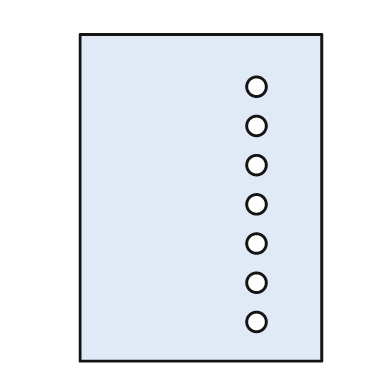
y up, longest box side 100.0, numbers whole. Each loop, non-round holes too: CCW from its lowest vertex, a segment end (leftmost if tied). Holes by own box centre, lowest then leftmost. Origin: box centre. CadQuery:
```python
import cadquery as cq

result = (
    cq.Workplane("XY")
    .moveTo(-37.0, -50.0)
    .lineTo(37.0, -50.0)
    .lineTo(37.0, 50.0)
    .lineTo(-37.0, 50.0)
    .close()
    .moveTo(17.0, -38.0)
    .circle(3.0)
    .moveTo(17.0, -26.0)
    .circle(3.0)
    .moveTo(17.0, -14.0)
    .circle(3.0)
    .moveTo(17.0, -2.0)
    .circle(3.0)
    .moveTo(17.0, 10.0)
    .circle(3.0)
    .moveTo(17.0, 22.0)
    .circle(3.0)
    .moveTo(17.0, 34.0)
    .circle(3.0)
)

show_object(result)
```